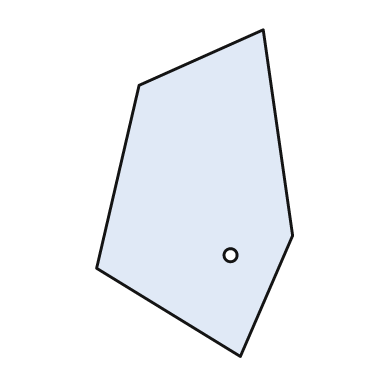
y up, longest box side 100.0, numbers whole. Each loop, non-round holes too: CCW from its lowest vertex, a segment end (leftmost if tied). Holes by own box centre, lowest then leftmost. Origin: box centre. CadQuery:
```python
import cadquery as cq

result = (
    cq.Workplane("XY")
    .moveTo(14.0, -50.0)
    .lineTo(30.0, -13.0)
    .lineTo(21.0, 50.0)
    .lineTo(-17.0, 33.0)
    .lineTo(-30.0, -23.0)
    .close()
    .moveTo(11.0, -19.0)
    .circle(2.0)
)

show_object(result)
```